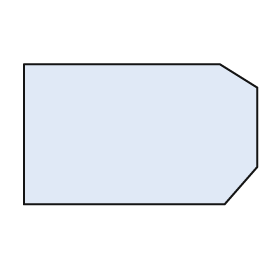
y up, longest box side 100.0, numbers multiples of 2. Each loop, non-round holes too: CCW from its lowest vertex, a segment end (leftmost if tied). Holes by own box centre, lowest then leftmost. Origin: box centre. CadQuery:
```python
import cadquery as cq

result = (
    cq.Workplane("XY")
    .moveTo(-50.0, -30.0)
    .lineTo(36.0, -30.0)
    .lineTo(50.0, -14.0)
    .lineTo(50.0, 20.0)
    .lineTo(34.0, 30.0)
    .lineTo(-50.0, 30.0)
    .close()
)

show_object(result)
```